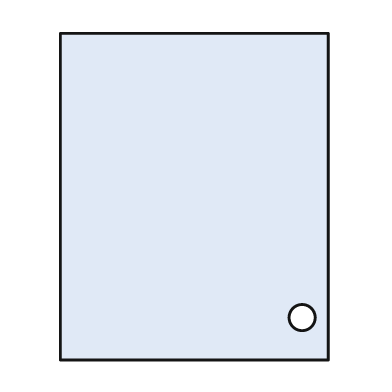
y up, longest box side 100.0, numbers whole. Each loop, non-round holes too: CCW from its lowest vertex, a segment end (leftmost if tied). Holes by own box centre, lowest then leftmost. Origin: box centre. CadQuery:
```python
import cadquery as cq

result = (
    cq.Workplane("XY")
    .moveTo(-41.0, -50.0)
    .lineTo(41.0, -50.0)
    .lineTo(41.0, 50.0)
    .lineTo(-41.0, 50.0)
    .close()
    .moveTo(33.0, -37.0)
    .circle(4.0)
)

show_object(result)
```